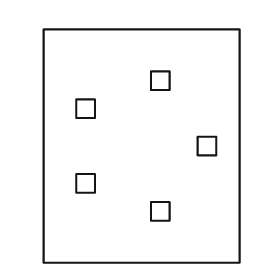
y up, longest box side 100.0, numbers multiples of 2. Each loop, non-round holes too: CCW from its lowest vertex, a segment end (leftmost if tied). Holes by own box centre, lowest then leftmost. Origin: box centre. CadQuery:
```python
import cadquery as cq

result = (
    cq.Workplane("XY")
    .moveTo(-42.0, -50.0)
    .lineTo(42.0, -50.0)
    .lineTo(42.0, 50.0)
    .lineTo(-42.0, 50.0)
    .close()
    .moveTo(4.0, -32.0)
    .lineTo(12.0, -32.0)
    .lineTo(12.0, -24.0)
    .lineTo(4.0, -24.0)
    .close()
    .moveTo(-28.0, -20.0)
    .lineTo(-20.0, -20.0)
    .lineTo(-20.0, -12.0)
    .lineTo(-28.0, -12.0)
    .close()
    .moveTo(24.0, -4.0)
    .lineTo(32.0, -4.0)
    .lineTo(32.0, 4.0)
    .lineTo(24.0, 4.0)
    .close()
    .moveTo(-28.0, 12.0)
    .lineTo(-20.0, 12.0)
    .lineTo(-20.0, 20.0)
    .lineTo(-28.0, 20.0)
    .close()
    .moveTo(4.0, 24.0)
    .lineTo(12.0, 24.0)
    .lineTo(12.0, 32.0)
    .lineTo(4.0, 32.0)
    .close()
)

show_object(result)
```